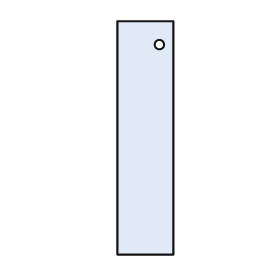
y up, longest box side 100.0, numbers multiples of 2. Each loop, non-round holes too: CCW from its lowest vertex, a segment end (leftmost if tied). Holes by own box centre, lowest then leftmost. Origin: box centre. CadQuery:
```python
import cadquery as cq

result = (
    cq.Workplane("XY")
    .moveTo(-12.0, -50.0)
    .lineTo(12.0, -50.0)
    .lineTo(12.0, 50.0)
    .lineTo(-12.0, 50.0)
    .close()
    .moveTo(6.0, 40.0)
    .circle(2.0)
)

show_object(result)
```